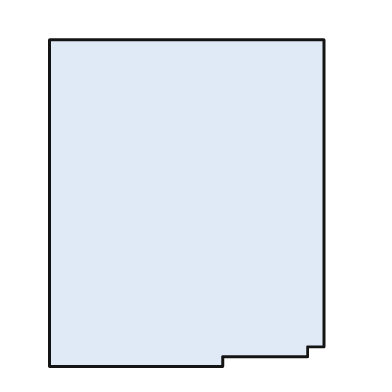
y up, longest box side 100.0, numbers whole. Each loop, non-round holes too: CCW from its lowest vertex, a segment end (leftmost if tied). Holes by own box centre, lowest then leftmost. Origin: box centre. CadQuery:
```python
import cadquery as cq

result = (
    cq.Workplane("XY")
    .moveTo(-42.0, -50.0)
    .lineTo(11.0, -50.0)
    .lineTo(11.0, -47.0)
    .lineTo(37.0, -47.0)
    .lineTo(37.0, -44.0)
    .lineTo(42.0, -44.0)
    .lineTo(42.0, 50.0)
    .lineTo(-42.0, 50.0)
    .close()
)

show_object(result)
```